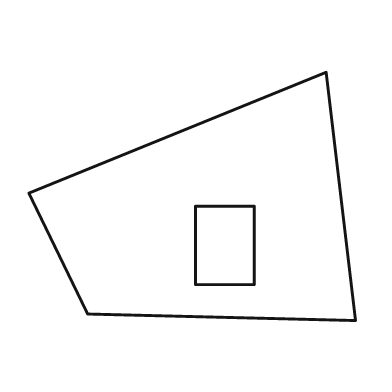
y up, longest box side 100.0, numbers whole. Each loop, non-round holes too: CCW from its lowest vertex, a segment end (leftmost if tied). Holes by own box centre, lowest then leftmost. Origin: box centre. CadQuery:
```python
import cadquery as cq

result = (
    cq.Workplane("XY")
    .moveTo(50.0, -38.0)
    .lineTo(41.0, 38.0)
    .lineTo(-50.0, 1.0)
    .lineTo(-32.0, -36.0)
    .close()
    .moveTo(1.0, -27.0)
    .lineTo(19.0, -27.0)
    .lineTo(19.0, -3.0)
    .lineTo(1.0, -3.0)
    .close()
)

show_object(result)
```